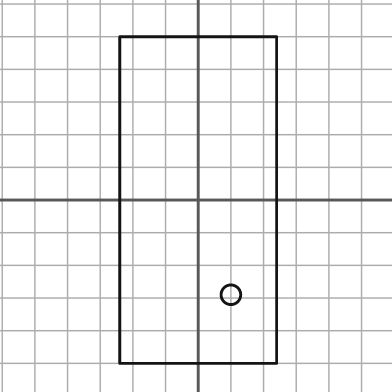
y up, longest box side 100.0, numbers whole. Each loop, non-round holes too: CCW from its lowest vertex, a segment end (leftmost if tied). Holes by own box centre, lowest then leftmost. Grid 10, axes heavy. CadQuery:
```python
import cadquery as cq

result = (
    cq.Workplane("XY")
    .moveTo(-24.0, -50.0)
    .lineTo(24.0, -50.0)
    .lineTo(24.0, 50.0)
    .lineTo(-24.0, 50.0)
    .close()
    .moveTo(10.0, -29.0)
    .circle(3.0)
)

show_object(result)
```